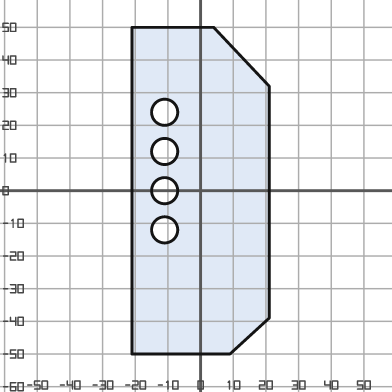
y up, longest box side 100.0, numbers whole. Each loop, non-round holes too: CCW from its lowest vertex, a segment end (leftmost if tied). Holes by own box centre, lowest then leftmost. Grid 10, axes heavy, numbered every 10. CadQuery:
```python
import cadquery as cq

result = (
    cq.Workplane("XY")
    .moveTo(-21.0, -50.0)
    .lineTo(9.0, -50.0)
    .lineTo(21.0, -39.0)
    .lineTo(21.0, 32.0)
    .lineTo(4.0, 50.0)
    .lineTo(-21.0, 50.0)
    .close()
    .moveTo(-11.0, -12.0)
    .circle(4.0)
    .moveTo(-11.0, 0.0)
    .circle(4.0)
    .moveTo(-11.0, 12.0)
    .circle(4.0)
    .moveTo(-11.0, 24.0)
    .circle(4.0)
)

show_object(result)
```